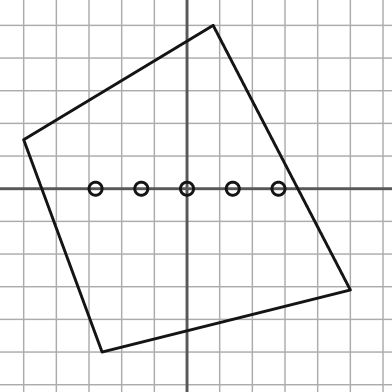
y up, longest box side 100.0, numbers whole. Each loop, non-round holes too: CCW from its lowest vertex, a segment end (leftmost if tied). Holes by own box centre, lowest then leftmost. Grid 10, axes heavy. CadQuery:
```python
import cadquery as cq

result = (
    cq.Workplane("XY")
    .moveTo(-26.0, -50.0)
    .lineTo(50.0, -31.0)
    .lineTo(8.0, 50.0)
    .lineTo(-50.0, 15.0)
    .close()
    .moveTo(-28.0, 0.0)
    .circle(2.0)
    .moveTo(-14.0, 0.0)
    .circle(2.0)
    .moveTo(0.0, 0.0)
    .circle(2.0)
    .moveTo(14.0, 0.0)
    .circle(2.0)
    .moveTo(28.0, 0.0)
    .circle(2.0)
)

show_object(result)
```